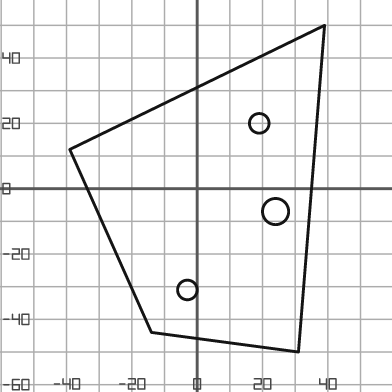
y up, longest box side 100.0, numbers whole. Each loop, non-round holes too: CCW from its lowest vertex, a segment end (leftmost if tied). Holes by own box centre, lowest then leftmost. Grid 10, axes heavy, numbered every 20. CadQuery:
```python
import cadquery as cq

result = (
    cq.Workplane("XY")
    .moveTo(31.0, -50.0)
    .lineTo(39.0, 50.0)
    .lineTo(-39.0, 12.0)
    .lineTo(-14.0, -44.0)
    .close()
    .moveTo(-3.0, -31.0)
    .circle(3.0)
    .moveTo(24.0, -7.0)
    .circle(4.0)
    .moveTo(19.0, 20.0)
    .circle(3.0)
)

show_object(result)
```